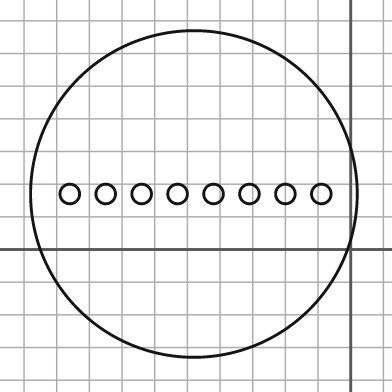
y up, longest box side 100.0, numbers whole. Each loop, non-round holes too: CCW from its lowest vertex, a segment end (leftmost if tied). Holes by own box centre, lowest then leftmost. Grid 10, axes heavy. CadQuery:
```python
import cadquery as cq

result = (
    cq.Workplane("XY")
    .moveTo(-48.0, 17.0)
    .circle(50.0)
    .moveTo(-86.0, 17.0)
    .circle(3.0)
    .moveTo(-75.0, 17.0)
    .circle(3.0)
    .moveTo(-64.0, 17.0)
    .circle(3.0)
    .moveTo(-53.0, 17.0)
    .circle(3.0)
    .moveTo(-42.0, 17.0)
    .circle(3.0)
    .moveTo(-31.0, 17.0)
    .circle(3.0)
    .moveTo(-20.0, 17.0)
    .circle(3.0)
    .moveTo(-9.0, 17.0)
    .circle(3.0)
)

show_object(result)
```